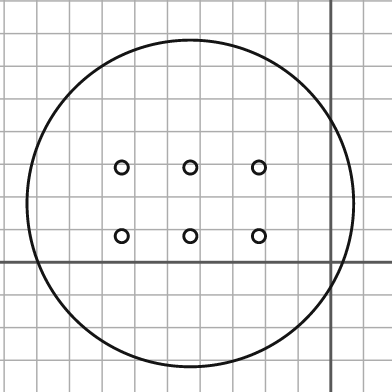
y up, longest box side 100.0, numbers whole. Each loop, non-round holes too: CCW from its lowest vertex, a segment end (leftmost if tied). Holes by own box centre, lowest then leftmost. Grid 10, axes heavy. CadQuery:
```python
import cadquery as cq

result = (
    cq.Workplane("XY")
    .moveTo(-43.0, 18.0)
    .circle(50.0)
    .moveTo(-64.0, 8.0)
    .circle(2.0)
    .moveTo(-43.0, 8.0)
    .circle(2.0)
    .moveTo(-22.0, 8.0)
    .circle(2.0)
    .moveTo(-64.0, 29.0)
    .circle(2.0)
    .moveTo(-43.0, 29.0)
    .circle(2.0)
    .moveTo(-22.0, 29.0)
    .circle(2.0)
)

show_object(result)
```